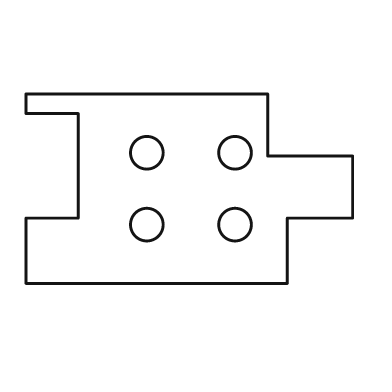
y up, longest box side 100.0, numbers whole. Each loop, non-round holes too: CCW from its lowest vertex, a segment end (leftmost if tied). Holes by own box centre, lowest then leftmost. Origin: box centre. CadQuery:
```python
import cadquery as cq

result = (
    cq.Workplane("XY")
    .moveTo(-50.0, -29.0)
    .lineTo(30.0, -29.0)
    .lineTo(30.0, -9.0)
    .lineTo(50.0, -9.0)
    .lineTo(50.0, 10.0)
    .lineTo(24.0, 10.0)
    .lineTo(24.0, 29.0)
    .lineTo(-50.0, 29.0)
    .lineTo(-50.0, 23.0)
    .lineTo(-34.0, 23.0)
    .lineTo(-34.0, -9.0)
    .lineTo(-50.0, -9.0)
    .close()
    .moveTo(-13.0, -11.0)
    .circle(5.0)
    .moveTo(14.0, -11.0)
    .circle(5.0)
    .moveTo(-13.0, 11.0)
    .circle(5.0)
    .moveTo(14.0, 11.0)
    .circle(5.0)
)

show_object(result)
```